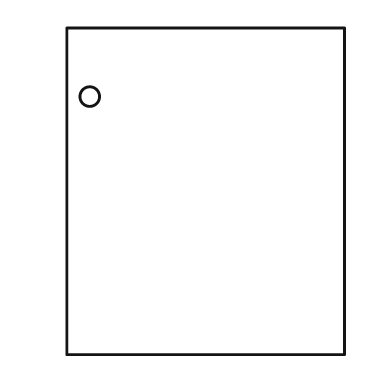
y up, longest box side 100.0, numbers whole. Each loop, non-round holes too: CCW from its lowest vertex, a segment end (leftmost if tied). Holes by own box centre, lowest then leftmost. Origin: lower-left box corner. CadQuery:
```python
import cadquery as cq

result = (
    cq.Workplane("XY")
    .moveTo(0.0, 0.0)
    .lineTo(85.0, 0.0)
    .lineTo(85.0, 100.0)
    .lineTo(0.0, 100.0)
    .close()
    .moveTo(7.0, 79.0)
    .circle(3.0)
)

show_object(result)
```